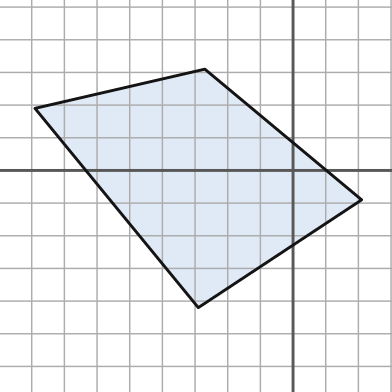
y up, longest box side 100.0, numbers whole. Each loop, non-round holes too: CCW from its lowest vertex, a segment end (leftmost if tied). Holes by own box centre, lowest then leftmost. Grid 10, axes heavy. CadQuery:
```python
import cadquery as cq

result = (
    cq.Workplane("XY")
    .moveTo(-29.0, -42.0)
    .lineTo(21.0, -9.0)
    .lineTo(-27.0, 31.0)
    .lineTo(-79.0, 19.0)
    .close()
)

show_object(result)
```